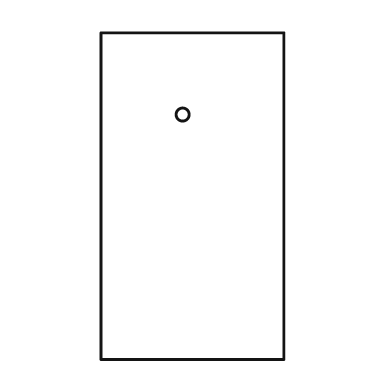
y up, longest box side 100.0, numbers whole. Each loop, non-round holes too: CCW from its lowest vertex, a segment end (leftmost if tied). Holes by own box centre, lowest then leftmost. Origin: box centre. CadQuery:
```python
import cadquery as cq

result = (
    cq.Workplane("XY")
    .moveTo(-28.0, -50.0)
    .lineTo(28.0, -50.0)
    .lineTo(28.0, 50.0)
    .lineTo(-28.0, 50.0)
    .close()
    .moveTo(-3.0, 25.0)
    .circle(2.0)
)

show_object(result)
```